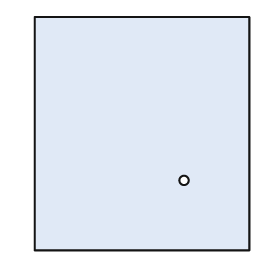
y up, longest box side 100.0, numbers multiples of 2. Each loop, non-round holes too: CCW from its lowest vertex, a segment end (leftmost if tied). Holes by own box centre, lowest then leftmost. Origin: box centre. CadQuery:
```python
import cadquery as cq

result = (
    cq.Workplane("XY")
    .moveTo(-46.0, -50.0)
    .lineTo(46.0, -50.0)
    .lineTo(46.0, 50.0)
    .lineTo(-46.0, 50.0)
    .close()
    .moveTo(18.0, -20.0)
    .circle(2.0)
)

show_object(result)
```